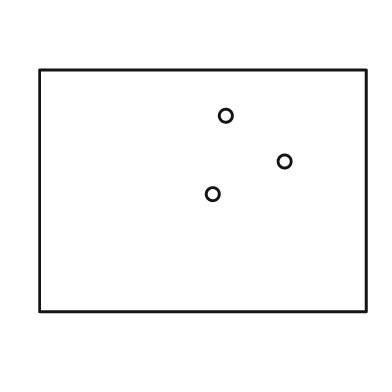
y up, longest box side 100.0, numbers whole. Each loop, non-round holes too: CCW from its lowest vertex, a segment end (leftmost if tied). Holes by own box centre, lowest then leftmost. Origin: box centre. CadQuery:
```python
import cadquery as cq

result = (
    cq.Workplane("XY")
    .moveTo(-50.0, -37.0)
    .lineTo(50.0, -37.0)
    .lineTo(50.0, 37.0)
    .lineTo(-50.0, 37.0)
    .close()
    .moveTo(3.0, -1.0)
    .circle(2.0)
    .moveTo(25.0, 9.0)
    .circle(2.0)
    .moveTo(7.0, 23.0)
    .circle(2.0)
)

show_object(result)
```